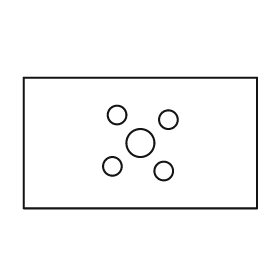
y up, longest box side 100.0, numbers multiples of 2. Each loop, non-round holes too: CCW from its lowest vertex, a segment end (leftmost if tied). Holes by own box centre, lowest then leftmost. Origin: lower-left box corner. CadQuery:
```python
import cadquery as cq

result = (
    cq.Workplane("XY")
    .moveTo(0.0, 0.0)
    .lineTo(100.0, 0.0)
    .lineTo(100.0, 56.0)
    .lineTo(0.0, 56.0)
    .close()
    .moveTo(60.0, 16.0)
    .circle(4.0)
    .moveTo(38.0, 18.0)
    .circle(4.0)
    .moveTo(50.0, 28.0)
    .circle(6.0)
    .moveTo(62.0, 38.0)
    .circle(4.0)
    .moveTo(40.0, 40.0)
    .circle(4.0)
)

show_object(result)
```